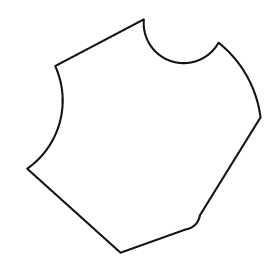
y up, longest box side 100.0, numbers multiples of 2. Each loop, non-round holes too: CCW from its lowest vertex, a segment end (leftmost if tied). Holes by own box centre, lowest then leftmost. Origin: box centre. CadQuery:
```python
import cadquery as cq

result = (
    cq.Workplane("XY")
    .moveTo(-10.0, -50.0)
    .lineTo(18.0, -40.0)
    .threePointArc((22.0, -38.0), (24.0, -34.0))
    .lineTo(50.0, 8.0)
    .threePointArc((44.0, 26.0), (32.0, 40.0))
    .threePointArc((12.0, 32.0), (0.0, 50.0))
    .lineTo(-38.0, 30.0)
    .threePointArc((-36.0, 6.0), (-50.0, -14.0))
    .close()
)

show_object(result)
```